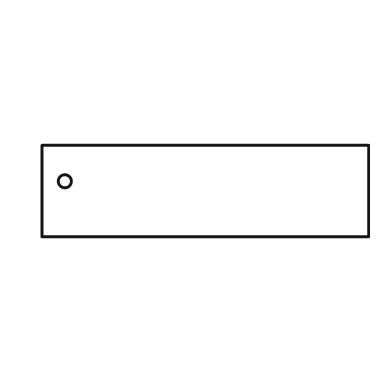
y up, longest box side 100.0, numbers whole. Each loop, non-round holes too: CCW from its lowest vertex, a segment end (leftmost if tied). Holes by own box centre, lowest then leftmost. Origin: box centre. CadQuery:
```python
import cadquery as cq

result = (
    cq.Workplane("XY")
    .moveTo(-50.0, -14.0)
    .lineTo(50.0, -14.0)
    .lineTo(50.0, 14.0)
    .lineTo(-50.0, 14.0)
    .close()
    .moveTo(-43.0, 3.0)
    .circle(2.0)
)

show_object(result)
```